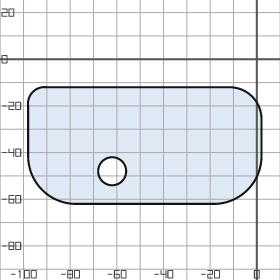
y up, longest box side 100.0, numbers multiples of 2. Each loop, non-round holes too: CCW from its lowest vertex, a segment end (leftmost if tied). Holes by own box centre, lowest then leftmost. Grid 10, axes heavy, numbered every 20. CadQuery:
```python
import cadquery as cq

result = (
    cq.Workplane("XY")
    .moveTo(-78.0, -62.0)
    .lineTo(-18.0, -62.0)
    .threePointArc((-4.0, -56.0), (2.0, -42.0))
    .lineTo(2.0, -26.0)
    .threePointArc((-2.0, -16.0), (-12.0, -12.0))
    .lineTo(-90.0, -12.0)
    .threePointArc((-96.0, -14.0), (-98.0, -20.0))
    .lineTo(-98.0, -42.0)
    .threePointArc((-92.0, -56.0), (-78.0, -62.0))
    .close()
    .moveTo(-62.0, -48.0)
    .circle(6.0)
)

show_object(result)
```